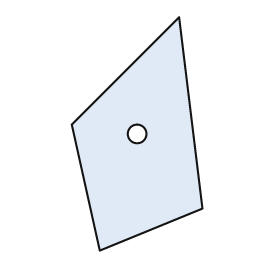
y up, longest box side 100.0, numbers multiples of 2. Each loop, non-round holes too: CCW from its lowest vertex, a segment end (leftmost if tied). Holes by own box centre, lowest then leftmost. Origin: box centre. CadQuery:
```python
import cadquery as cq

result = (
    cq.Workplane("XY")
    .moveTo(-16.0, -50.0)
    .lineTo(28.0, -32.0)
    .lineTo(18.0, 50.0)
    .lineTo(-28.0, 4.0)
    .close()
    .moveTo(0.0, 0.0)
    .circle(4.0)
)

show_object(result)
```